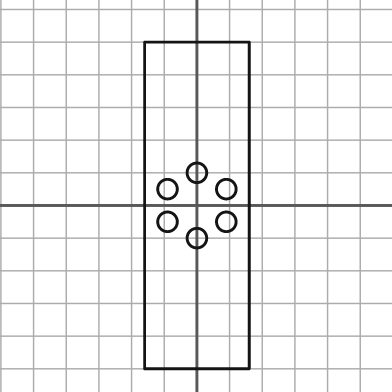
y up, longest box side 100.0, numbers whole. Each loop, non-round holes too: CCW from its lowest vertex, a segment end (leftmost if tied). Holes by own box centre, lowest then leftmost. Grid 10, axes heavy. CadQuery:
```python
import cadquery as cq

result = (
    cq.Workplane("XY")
    .moveTo(-16.0, -50.0)
    .lineTo(16.0, -50.0)
    .lineTo(16.0, 50.0)
    .lineTo(-16.0, 50.0)
    .close()
    .moveTo(0.0, -10.0)
    .circle(3.0)
    .moveTo(-9.0, -5.0)
    .circle(3.0)
    .moveTo(9.0, -5.0)
    .circle(3.0)
    .moveTo(-9.0, 5.0)
    .circle(3.0)
    .moveTo(9.0, 5.0)
    .circle(3.0)
    .moveTo(0.0, 10.0)
    .circle(3.0)
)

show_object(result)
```